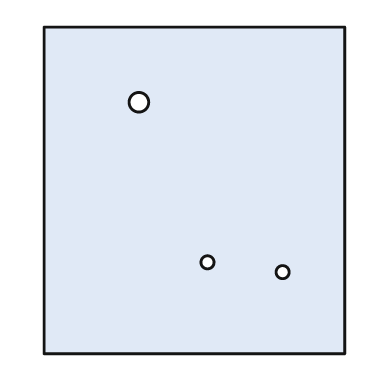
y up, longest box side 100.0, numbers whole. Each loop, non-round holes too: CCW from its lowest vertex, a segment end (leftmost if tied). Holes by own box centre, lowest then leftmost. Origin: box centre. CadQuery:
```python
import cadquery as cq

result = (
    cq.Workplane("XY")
    .moveTo(-46.0, -50.0)
    .lineTo(46.0, -50.0)
    .lineTo(46.0, 50.0)
    .lineTo(-46.0, 50.0)
    .close()
    .moveTo(27.0, -25.0)
    .circle(2.0)
    .moveTo(4.0, -22.0)
    .circle(2.0)
    .moveTo(-17.0, 27.0)
    .circle(3.0)
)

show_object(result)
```